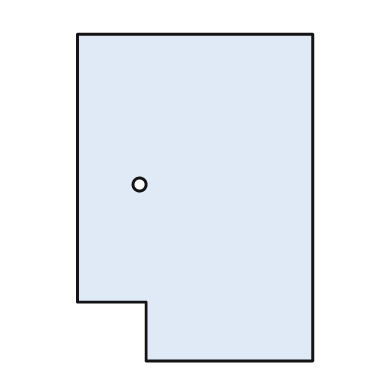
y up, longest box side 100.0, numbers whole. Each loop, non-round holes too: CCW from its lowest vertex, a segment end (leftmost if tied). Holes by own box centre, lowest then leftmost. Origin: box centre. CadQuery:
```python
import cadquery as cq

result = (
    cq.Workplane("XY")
    .moveTo(-15.0, -50.0)
    .lineTo(36.0, -50.0)
    .lineTo(36.0, 50.0)
    .lineTo(-36.0, 50.0)
    .lineTo(-36.0, -32.0)
    .lineTo(-15.0, -32.0)
    .close()
    .moveTo(-17.0, 4.0)
    .circle(2.0)
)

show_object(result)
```